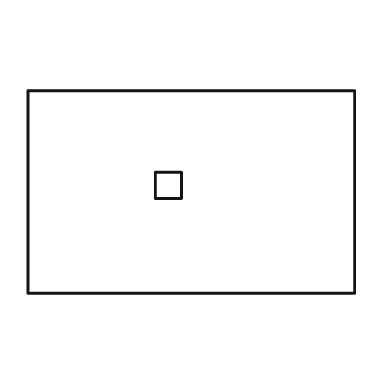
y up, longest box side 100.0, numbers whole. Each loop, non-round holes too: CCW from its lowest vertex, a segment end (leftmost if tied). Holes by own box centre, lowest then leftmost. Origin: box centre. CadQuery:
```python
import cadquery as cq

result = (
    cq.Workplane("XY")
    .moveTo(-50.0, -31.0)
    .lineTo(50.0, -31.0)
    .lineTo(50.0, 31.0)
    .lineTo(-50.0, 31.0)
    .close()
    .moveTo(-11.0, -2.0)
    .lineTo(-3.0, -2.0)
    .lineTo(-3.0, 6.0)
    .lineTo(-11.0, 6.0)
    .close()
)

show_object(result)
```